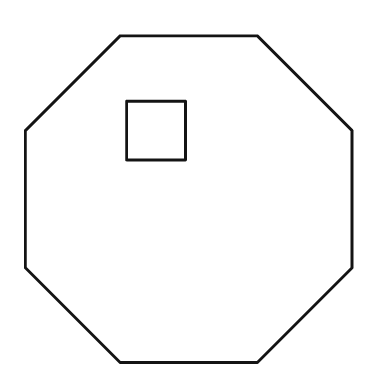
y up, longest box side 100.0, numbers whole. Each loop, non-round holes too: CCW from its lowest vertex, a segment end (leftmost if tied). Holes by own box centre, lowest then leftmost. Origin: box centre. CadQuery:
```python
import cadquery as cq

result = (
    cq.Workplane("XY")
    .moveTo(-21.0, -50.0)
    .lineTo(21.0, -50.0)
    .lineTo(50.0, -21.0)
    .lineTo(50.0, 21.0)
    .lineTo(21.0, 50.0)
    .lineTo(-21.0, 50.0)
    .lineTo(-50.0, 21.0)
    .lineTo(-50.0, -21.0)
    .close()
    .moveTo(-19.0, 12.0)
    .lineTo(-1.0, 12.0)
    .lineTo(-1.0, 30.0)
    .lineTo(-19.0, 30.0)
    .close()
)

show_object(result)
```